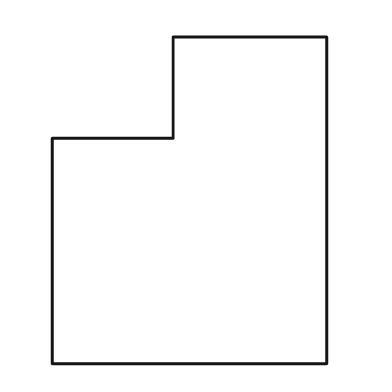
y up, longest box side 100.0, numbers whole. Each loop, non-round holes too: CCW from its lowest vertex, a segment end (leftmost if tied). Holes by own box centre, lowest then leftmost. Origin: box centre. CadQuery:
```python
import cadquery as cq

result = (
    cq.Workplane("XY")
    .moveTo(-42.0, -50.0)
    .lineTo(42.0, -50.0)
    .lineTo(42.0, 50.0)
    .lineTo(-5.0, 50.0)
    .lineTo(-5.0, 19.0)
    .lineTo(-42.0, 19.0)
    .close()
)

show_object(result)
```